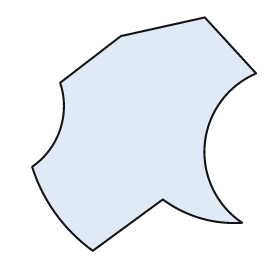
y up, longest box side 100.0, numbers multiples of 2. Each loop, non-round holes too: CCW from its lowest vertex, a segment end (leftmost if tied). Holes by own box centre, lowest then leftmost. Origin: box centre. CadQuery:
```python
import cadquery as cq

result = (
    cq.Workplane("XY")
    .moveTo(-22.0, -50.0)
    .lineTo(8.0, -28.0)
    .threePointArc((24.0, -36.0), (42.0, -38.0))
    .threePointArc((26.0, -4.0), (48.0, 26.0))
    .lineTo(26.0, 50.0)
    .lineTo(-10.0, 42.0)
    .lineTo(-36.0, 22.0)
    .threePointArc((-36.0, 2.0), (-48.0, -14.0))
    .threePointArc((-38.0, -34.0), (-22.0, -50.0))
    .close()
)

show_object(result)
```